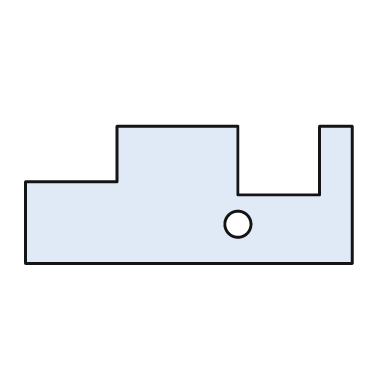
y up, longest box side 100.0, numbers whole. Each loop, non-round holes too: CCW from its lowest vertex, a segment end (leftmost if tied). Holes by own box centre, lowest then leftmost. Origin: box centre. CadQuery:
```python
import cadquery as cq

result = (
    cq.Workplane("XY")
    .moveTo(-50.0, -21.0)
    .lineTo(50.0, -21.0)
    .lineTo(50.0, 21.0)
    .lineTo(40.0, 21.0)
    .lineTo(40.0, 0.0)
    .lineTo(15.0, 0.0)
    .lineTo(15.0, 21.0)
    .lineTo(-22.0, 21.0)
    .lineTo(-22.0, 4.0)
    .lineTo(-50.0, 4.0)
    .close()
    .moveTo(15.0, -9.0)
    .circle(4.0)
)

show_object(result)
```